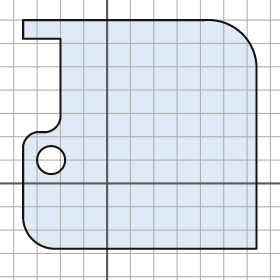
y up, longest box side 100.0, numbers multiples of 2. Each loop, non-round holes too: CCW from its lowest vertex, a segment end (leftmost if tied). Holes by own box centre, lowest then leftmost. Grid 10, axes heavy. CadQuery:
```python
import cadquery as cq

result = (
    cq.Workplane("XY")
    .moveTo(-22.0, -28.0)
    .lineTo(64.0, -28.0)
    .lineTo(64.0, 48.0)
    .threePointArc((58.0, 64.0), (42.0, 70.0))
    .lineTo(-36.0, 70.0)
    .lineTo(-36.0, 62.0)
    .lineTo(-20.0, 62.0)
    .lineTo(-20.0, 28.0)
    .threePointArc((-22.0, 24.0), (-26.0, 22.0))
    .lineTo(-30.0, 22.0)
    .threePointArc((-34.0, 20.0), (-36.0, 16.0))
    .lineTo(-36.0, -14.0)
    .threePointArc((-32.0, -24.0), (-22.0, -28.0))
    .close()
    .moveTo(-24.0, 10.0)
    .circle(6.0)
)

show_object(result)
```